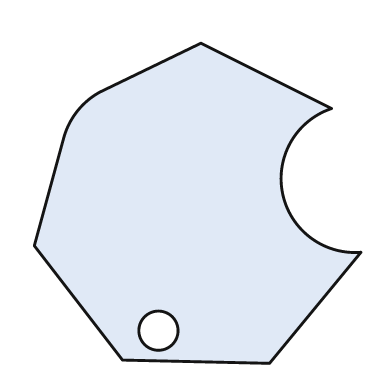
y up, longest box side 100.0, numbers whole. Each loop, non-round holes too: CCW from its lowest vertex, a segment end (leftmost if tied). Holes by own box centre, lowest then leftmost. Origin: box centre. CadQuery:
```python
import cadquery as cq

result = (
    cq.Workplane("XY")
    .moveTo(22.0, -49.0)
    .lineTo(50.0, -15.0)
    .threePointArc((26.0, 3.0), (41.0, 29.0))
    .lineTo(1.0, 49.0)
    .lineTo(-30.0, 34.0)
    .threePointArc((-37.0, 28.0), (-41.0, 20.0))
    .lineTo(-50.0, -13.0)
    .lineTo(-23.0, -48.0)
    .close()
    .moveTo(-12.0, -39.0)
    .circle(6.0)
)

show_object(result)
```